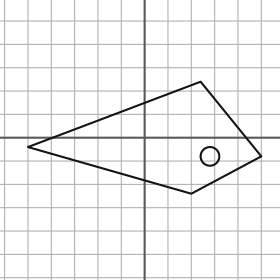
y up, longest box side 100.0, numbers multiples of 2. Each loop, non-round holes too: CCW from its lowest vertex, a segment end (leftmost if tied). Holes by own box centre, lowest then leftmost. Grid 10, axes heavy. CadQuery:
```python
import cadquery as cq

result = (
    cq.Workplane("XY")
    .moveTo(20.0, -24.0)
    .lineTo(50.0, -8.0)
    .lineTo(24.0, 24.0)
    .lineTo(-50.0, -4.0)
    .close()
    .moveTo(28.0, -8.0)
    .circle(4.0)
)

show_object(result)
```